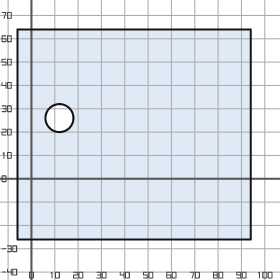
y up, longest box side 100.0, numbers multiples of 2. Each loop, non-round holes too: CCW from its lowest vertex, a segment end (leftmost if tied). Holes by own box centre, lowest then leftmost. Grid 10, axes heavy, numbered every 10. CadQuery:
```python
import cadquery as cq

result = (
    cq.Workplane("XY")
    .moveTo(-6.0, -26.0)
    .lineTo(94.0, -26.0)
    .lineTo(94.0, 64.0)
    .lineTo(-6.0, 64.0)
    .close()
    .moveTo(12.0, 26.0)
    .circle(6.0)
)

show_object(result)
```